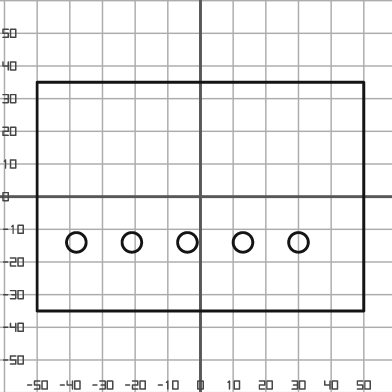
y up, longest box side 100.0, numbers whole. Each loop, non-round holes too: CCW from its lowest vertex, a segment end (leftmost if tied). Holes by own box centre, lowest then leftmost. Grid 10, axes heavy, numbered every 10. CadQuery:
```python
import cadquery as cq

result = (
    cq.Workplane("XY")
    .moveTo(-50.0, -35.0)
    .lineTo(50.0, -35.0)
    .lineTo(50.0, 35.0)
    .lineTo(-50.0, 35.0)
    .close()
    .moveTo(-38.0, -14.0)
    .circle(3.0)
    .moveTo(-21.0, -14.0)
    .circle(3.0)
    .moveTo(-4.0, -14.0)
    .circle(3.0)
    .moveTo(13.0, -14.0)
    .circle(3.0)
    .moveTo(30.0, -14.0)
    .circle(3.0)
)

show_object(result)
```